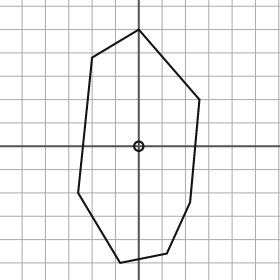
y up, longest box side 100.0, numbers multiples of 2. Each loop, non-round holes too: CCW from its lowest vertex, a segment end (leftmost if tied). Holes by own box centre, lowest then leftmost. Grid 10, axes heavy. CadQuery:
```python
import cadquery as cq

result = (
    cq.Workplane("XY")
    .moveTo(-8.0, -50.0)
    .lineTo(12.0, -46.0)
    .lineTo(22.0, -24.0)
    .lineTo(26.0, 20.0)
    .lineTo(0.0, 50.0)
    .lineTo(-20.0, 38.0)
    .lineTo(-26.0, -20.0)
    .close()
    .moveTo(0.0, 0.0)
    .circle(2.0)
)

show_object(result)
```